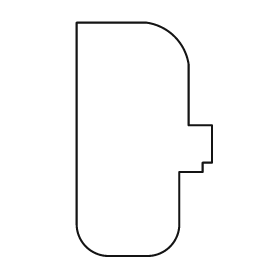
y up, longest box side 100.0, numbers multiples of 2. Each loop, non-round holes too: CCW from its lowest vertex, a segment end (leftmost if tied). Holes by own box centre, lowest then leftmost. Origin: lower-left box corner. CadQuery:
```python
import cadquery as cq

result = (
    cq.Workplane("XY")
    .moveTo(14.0, 0.0)
    .lineTo(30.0, 0.0)
    .threePointArc((40.0, 4.0), (44.0, 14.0))
    .lineTo(44.0, 36.0)
    .lineTo(54.0, 36.0)
    .lineTo(54.0, 40.0)
    .lineTo(58.0, 40.0)
    .lineTo(58.0, 56.0)
    .lineTo(48.0, 56.0)
    .lineTo(48.0, 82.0)
    .threePointArc((42.0, 94.0), (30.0, 100.0))
    .lineTo(0.0, 100.0)
    .lineTo(0.0, 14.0)
    .threePointArc((4.0, 4.0), (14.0, 0.0))
    .close()
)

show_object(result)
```